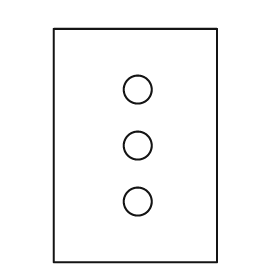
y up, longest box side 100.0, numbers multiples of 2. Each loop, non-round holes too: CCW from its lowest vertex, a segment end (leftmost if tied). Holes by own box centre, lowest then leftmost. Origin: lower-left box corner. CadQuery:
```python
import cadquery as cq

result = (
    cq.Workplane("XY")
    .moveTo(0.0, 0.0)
    .lineTo(70.0, 0.0)
    .lineTo(70.0, 100.0)
    .lineTo(0.0, 100.0)
    .close()
    .moveTo(36.0, 26.0)
    .circle(6.0)
    .moveTo(36.0, 50.0)
    .circle(6.0)
    .moveTo(36.0, 74.0)
    .circle(6.0)
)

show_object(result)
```